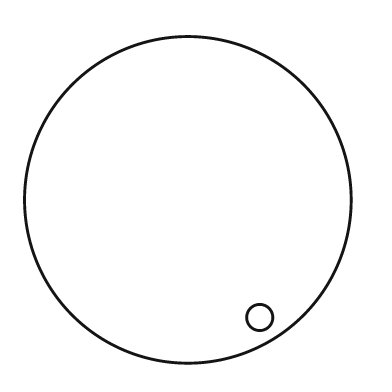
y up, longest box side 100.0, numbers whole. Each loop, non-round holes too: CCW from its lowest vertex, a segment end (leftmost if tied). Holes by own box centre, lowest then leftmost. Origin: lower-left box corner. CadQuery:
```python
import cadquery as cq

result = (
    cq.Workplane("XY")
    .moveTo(50.0, 50.0)
    .circle(50.0)
    .moveTo(72.0, 14.0)
    .circle(4.0)
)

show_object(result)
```